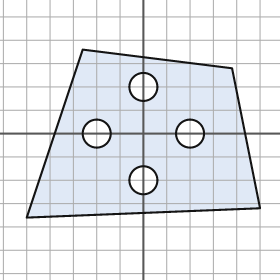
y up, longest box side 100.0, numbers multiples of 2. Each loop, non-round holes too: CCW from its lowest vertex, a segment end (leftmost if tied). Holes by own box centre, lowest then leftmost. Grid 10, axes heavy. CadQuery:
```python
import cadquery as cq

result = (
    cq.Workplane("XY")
    .moveTo(-50.0, -36.0)
    .lineTo(50.0, -32.0)
    .lineTo(38.0, 28.0)
    .lineTo(-26.0, 36.0)
    .close()
    .moveTo(0.0, -20.0)
    .circle(6.0)
    .moveTo(-20.0, 0.0)
    .circle(6.0)
    .moveTo(20.0, 0.0)
    .circle(6.0)
    .moveTo(0.0, 20.0)
    .circle(6.0)
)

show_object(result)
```